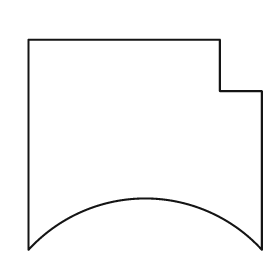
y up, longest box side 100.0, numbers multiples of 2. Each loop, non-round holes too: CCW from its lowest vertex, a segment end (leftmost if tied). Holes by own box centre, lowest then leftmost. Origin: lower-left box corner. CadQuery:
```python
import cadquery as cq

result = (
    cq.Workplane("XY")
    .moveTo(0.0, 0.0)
    .threePointArc((50.0, 22.0), (100.0, 0.0))
    .lineTo(100.0, 68.0)
    .lineTo(82.0, 68.0)
    .lineTo(82.0, 90.0)
    .lineTo(0.0, 90.0)
    .close()
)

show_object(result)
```